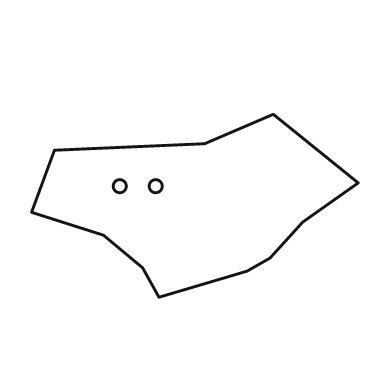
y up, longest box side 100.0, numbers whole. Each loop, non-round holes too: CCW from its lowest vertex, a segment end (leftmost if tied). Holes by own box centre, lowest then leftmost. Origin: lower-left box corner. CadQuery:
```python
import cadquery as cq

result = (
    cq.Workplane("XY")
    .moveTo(39.0, 0.0)
    .lineTo(66.0, 8.0)
    .lineTo(73.0, 12.0)
    .lineTo(83.0, 23.0)
    .lineTo(100.0, 35.0)
    .lineTo(74.0, 56.0)
    .lineTo(53.0, 47.0)
    .lineTo(7.0, 45.0)
    .lineTo(0.0, 26.0)
    .lineTo(22.0, 19.0)
    .lineTo(34.0, 9.0)
    .close()
    .moveTo(27.0, 34.0)
    .circle(2.0)
    .moveTo(38.0, 34.0)
    .circle(2.0)
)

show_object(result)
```